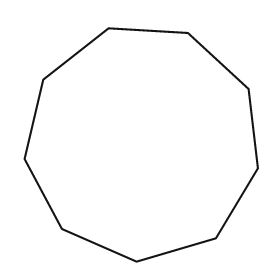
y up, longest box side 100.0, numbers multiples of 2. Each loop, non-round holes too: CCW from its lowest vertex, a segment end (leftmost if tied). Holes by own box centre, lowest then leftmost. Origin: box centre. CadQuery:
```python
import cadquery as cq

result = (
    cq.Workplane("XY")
    .moveTo(-2.0, -50.0)
    .lineTo(32.0, -40.0)
    .lineTo(50.0, -10.0)
    .lineTo(46.0, 24.0)
    .lineTo(20.0, 48.0)
    .lineTo(-14.0, 50.0)
    .lineTo(-42.0, 28.0)
    .lineTo(-50.0, -6.0)
    .lineTo(-34.0, -36.0)
    .close()
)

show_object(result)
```